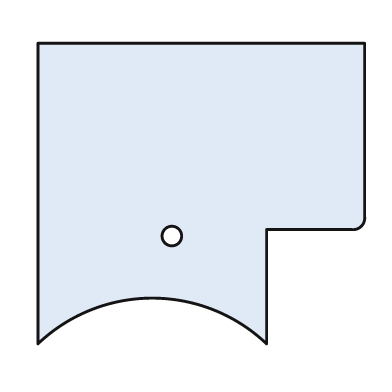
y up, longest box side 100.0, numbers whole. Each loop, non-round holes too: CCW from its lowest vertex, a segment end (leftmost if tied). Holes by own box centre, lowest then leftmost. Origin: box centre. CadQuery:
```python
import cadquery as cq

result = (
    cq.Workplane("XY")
    .moveTo(-50.0, -46.0)
    .threePointArc((-15.0, -32.0), (20.0, -46.0))
    .lineTo(20.0, -11.0)
    .lineTo(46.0, -11.0)
    .threePointArc((49.0, -10.0), (50.0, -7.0))
    .lineTo(50.0, 46.0)
    .lineTo(-50.0, 46.0)
    .close()
    .moveTo(-9.0, -13.0)
    .circle(3.0)
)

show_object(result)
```